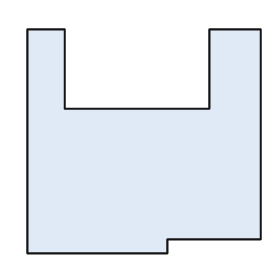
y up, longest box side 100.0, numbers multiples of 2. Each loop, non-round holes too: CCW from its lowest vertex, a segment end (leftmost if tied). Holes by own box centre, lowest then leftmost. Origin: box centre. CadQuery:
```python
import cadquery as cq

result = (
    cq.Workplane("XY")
    .moveTo(-50.0, -48.0)
    .lineTo(10.0, -48.0)
    .lineTo(10.0, -42.0)
    .lineTo(50.0, -42.0)
    .lineTo(50.0, 48.0)
    .lineTo(28.0, 48.0)
    .lineTo(28.0, 14.0)
    .lineTo(-34.0, 14.0)
    .lineTo(-34.0, 48.0)
    .lineTo(-50.0, 48.0)
    .close()
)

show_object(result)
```